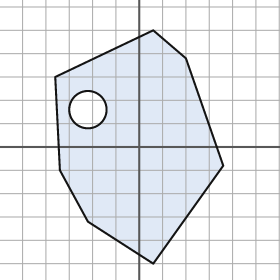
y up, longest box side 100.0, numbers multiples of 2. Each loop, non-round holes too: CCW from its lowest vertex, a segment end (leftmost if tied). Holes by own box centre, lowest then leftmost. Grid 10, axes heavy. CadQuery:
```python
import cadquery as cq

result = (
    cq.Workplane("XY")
    .moveTo(6.0, -50.0)
    .lineTo(36.0, -8.0)
    .lineTo(20.0, 38.0)
    .lineTo(6.0, 50.0)
    .lineTo(-36.0, 30.0)
    .lineTo(-34.0, -10.0)
    .lineTo(-22.0, -32.0)
    .close()
    .moveTo(-22.0, 16.0)
    .circle(8.0)
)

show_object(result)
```